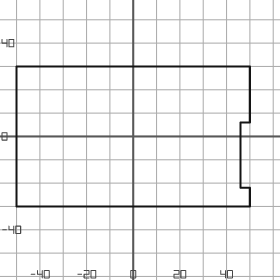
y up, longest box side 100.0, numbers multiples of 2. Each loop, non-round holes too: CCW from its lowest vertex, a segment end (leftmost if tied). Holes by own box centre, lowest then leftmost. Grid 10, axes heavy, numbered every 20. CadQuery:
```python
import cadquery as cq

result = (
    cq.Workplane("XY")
    .moveTo(-50.0, -30.0)
    .lineTo(50.0, -30.0)
    .lineTo(50.0, -22.0)
    .lineTo(46.0, -22.0)
    .lineTo(46.0, 6.0)
    .lineTo(50.0, 6.0)
    .lineTo(50.0, 30.0)
    .lineTo(-50.0, 30.0)
    .close()
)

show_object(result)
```